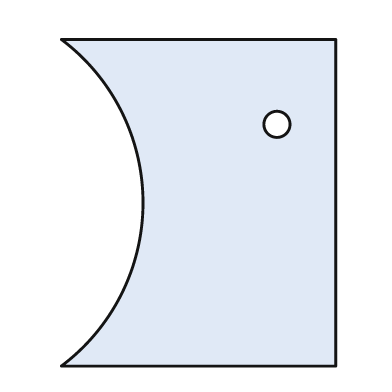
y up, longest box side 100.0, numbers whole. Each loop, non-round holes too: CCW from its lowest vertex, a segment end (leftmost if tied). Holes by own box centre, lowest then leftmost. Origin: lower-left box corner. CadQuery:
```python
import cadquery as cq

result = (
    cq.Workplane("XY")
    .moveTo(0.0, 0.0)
    .lineTo(84.0, 0.0)
    .lineTo(84.0, 100.0)
    .lineTo(0.0, 100.0)
    .threePointArc((25.0, 50.0), (0.0, 0.0))
    .close()
    .moveTo(66.0, 74.0)
    .circle(4.0)
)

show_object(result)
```